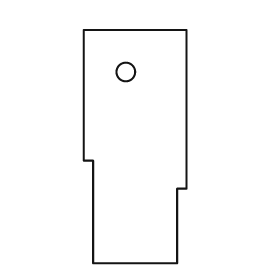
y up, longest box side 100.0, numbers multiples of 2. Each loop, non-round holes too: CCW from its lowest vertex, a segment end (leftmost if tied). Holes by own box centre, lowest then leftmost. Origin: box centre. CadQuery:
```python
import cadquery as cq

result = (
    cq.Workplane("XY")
    .moveTo(-18.0, -50.0)
    .lineTo(18.0, -50.0)
    .lineTo(18.0, -18.0)
    .lineTo(22.0, -18.0)
    .lineTo(22.0, 50.0)
    .lineTo(-22.0, 50.0)
    .lineTo(-22.0, -6.0)
    .lineTo(-18.0, -6.0)
    .close()
    .moveTo(-4.0, 32.0)
    .circle(4.0)
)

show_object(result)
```